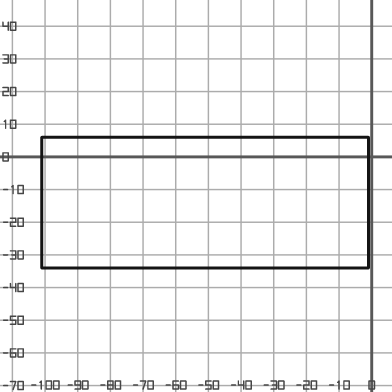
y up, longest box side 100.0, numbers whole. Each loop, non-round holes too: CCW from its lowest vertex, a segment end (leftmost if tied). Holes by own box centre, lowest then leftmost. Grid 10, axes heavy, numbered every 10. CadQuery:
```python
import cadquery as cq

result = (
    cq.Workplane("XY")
    .moveTo(-101.0, -34.0)
    .lineTo(-1.0, -34.0)
    .lineTo(-1.0, 6.0)
    .lineTo(-101.0, 6.0)
    .close()
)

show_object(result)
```